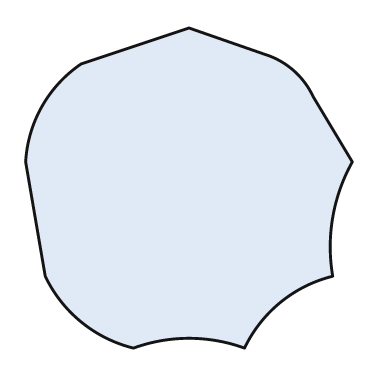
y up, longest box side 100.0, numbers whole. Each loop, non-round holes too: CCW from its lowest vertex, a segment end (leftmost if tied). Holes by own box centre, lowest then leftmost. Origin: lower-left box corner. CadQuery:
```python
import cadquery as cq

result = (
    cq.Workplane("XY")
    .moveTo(33.0, 0.0)
    .threePointArc((50.0, 3.0), (67.0, 0.0))
    .threePointArc((78.0, 14.0), (94.0, 22.0))
    .threePointArc((94.0, 40.0), (100.0, 57.0))
    .lineTo(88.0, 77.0)
    .threePointArc((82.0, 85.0), (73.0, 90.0))
    .lineTo(50.0, 98.0)
    .lineTo(17.0, 87.0)
    .threePointArc((5.0, 74.0), (0.0, 57.0))
    .lineTo(6.0, 22.0)
    .threePointArc((17.0, 8.0), (33.0, 0.0))
    .close()
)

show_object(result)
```